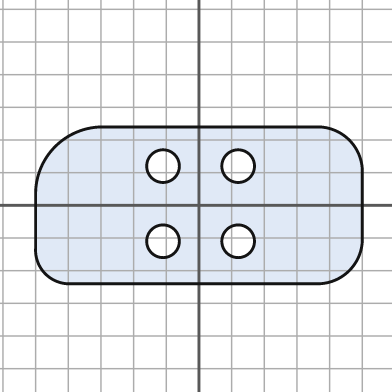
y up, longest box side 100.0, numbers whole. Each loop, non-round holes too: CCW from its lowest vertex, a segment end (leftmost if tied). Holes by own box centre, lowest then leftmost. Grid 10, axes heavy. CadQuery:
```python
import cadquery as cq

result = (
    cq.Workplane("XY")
    .moveTo(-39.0, -24.0)
    .lineTo(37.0, -24.0)
    .threePointArc((46.0, -20.0), (50.0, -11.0))
    .lineTo(50.0, 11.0)
    .threePointArc((46.0, 20.0), (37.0, 24.0))
    .lineTo(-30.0, 24.0)
    .threePointArc((-44.0, 18.0), (-50.0, 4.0))
    .lineTo(-50.0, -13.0)
    .threePointArc((-47.0, -21.0), (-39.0, -24.0))
    .close()
    .moveTo(-11.0, -11.0)
    .circle(5.0)
    .moveTo(12.0, -11.0)
    .circle(5.0)
    .moveTo(-11.0, 12.0)
    .circle(5.0)
    .moveTo(12.0, 12.0)
    .circle(5.0)
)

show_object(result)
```